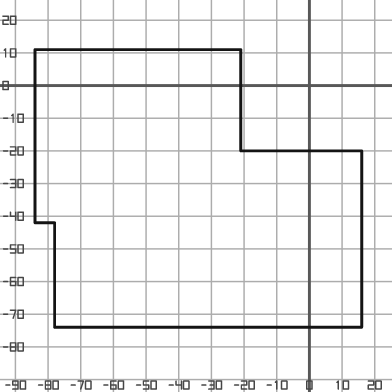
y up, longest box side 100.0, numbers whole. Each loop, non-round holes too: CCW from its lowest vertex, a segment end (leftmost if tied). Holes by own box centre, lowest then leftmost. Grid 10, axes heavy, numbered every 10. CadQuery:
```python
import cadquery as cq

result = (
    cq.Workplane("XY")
    .moveTo(-78.0, -74.0)
    .lineTo(16.0, -74.0)
    .lineTo(16.0, -20.0)
    .lineTo(-21.0, -20.0)
    .lineTo(-21.0, 11.0)
    .lineTo(-84.0, 11.0)
    .lineTo(-84.0, -42.0)
    .lineTo(-78.0, -42.0)
    .close()
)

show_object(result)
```